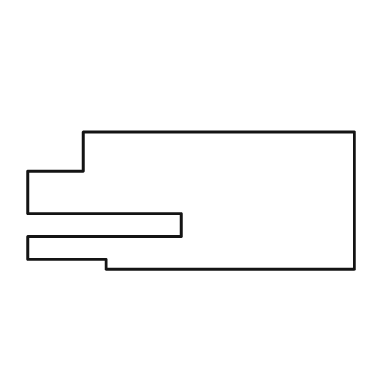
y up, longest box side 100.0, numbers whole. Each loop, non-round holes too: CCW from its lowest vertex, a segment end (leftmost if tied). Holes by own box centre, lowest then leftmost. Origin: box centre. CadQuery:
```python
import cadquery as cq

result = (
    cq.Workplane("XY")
    .moveTo(-26.0, -21.0)
    .lineTo(50.0, -21.0)
    .lineTo(50.0, 21.0)
    .lineTo(-33.0, 21.0)
    .lineTo(-33.0, 9.0)
    .lineTo(-50.0, 9.0)
    .lineTo(-50.0, -4.0)
    .lineTo(-3.0, -4.0)
    .lineTo(-3.0, -11.0)
    .lineTo(-50.0, -11.0)
    .lineTo(-50.0, -18.0)
    .lineTo(-26.0, -18.0)
    .close()
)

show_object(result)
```